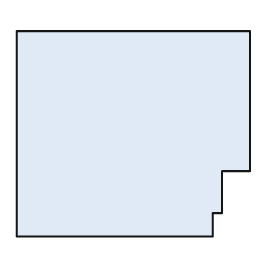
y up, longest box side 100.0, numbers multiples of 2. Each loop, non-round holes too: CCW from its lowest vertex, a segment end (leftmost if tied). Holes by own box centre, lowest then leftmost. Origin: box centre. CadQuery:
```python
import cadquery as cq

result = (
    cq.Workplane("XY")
    .moveTo(-50.0, -44.0)
    .lineTo(34.0, -44.0)
    .lineTo(34.0, -34.0)
    .lineTo(38.0, -34.0)
    .lineTo(38.0, -16.0)
    .lineTo(50.0, -16.0)
    .lineTo(50.0, 44.0)
    .lineTo(-50.0, 44.0)
    .close()
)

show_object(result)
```